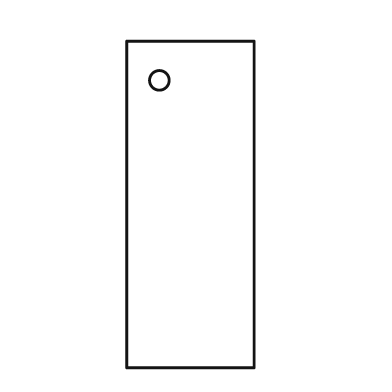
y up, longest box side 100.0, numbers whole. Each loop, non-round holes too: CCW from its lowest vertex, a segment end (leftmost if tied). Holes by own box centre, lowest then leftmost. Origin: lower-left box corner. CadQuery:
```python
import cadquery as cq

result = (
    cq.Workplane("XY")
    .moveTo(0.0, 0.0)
    .lineTo(39.0, 0.0)
    .lineTo(39.0, 100.0)
    .lineTo(0.0, 100.0)
    .close()
    .moveTo(10.0, 88.0)
    .circle(3.0)
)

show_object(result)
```